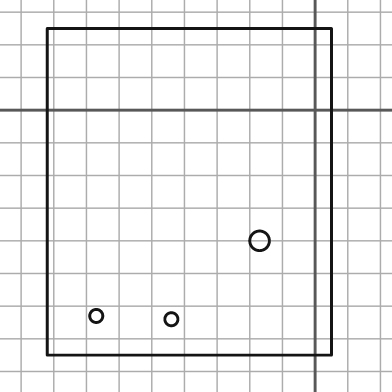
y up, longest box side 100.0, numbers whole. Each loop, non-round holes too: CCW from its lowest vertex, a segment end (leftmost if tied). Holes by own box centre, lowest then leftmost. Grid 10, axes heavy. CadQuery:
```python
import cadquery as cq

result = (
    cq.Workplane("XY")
    .moveTo(-82.0, -75.0)
    .lineTo(5.0, -75.0)
    .lineTo(5.0, 25.0)
    .lineTo(-82.0, 25.0)
    .close()
    .moveTo(-44.0, -64.0)
    .circle(2.0)
    .moveTo(-67.0, -63.0)
    .circle(2.0)
    .moveTo(-17.0, -40.0)
    .circle(3.0)
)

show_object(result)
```